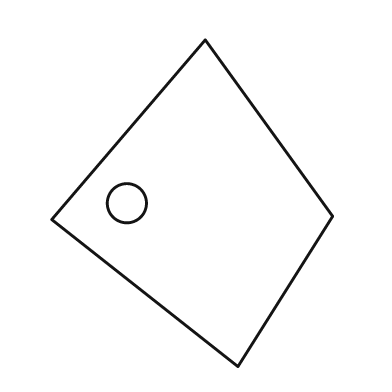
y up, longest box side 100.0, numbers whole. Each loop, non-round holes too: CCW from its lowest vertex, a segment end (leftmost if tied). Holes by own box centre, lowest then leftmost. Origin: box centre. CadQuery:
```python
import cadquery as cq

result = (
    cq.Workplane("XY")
    .moveTo(14.0, -50.0)
    .lineTo(43.0, -4.0)
    .lineTo(4.0, 50.0)
    .lineTo(-43.0, -5.0)
    .close()
    .moveTo(-20.0, 0.0)
    .circle(6.0)
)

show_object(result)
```